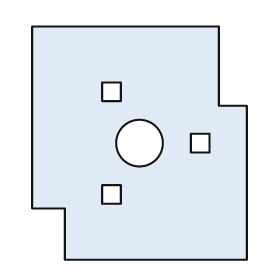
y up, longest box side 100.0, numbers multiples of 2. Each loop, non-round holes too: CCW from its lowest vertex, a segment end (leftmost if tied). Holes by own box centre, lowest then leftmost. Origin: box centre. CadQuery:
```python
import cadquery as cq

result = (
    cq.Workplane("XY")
    .moveTo(-32.0, -50.0)
    .lineTo(46.0, -50.0)
    .lineTo(46.0, 16.0)
    .lineTo(34.0, 16.0)
    .lineTo(34.0, 50.0)
    .lineTo(-46.0, 50.0)
    .lineTo(-46.0, -28.0)
    .lineTo(-32.0, -28.0)
    .close()
    .moveTo(-16.0, -26.0)
    .lineTo(-8.0, -26.0)
    .lineTo(-8.0, -18.0)
    .lineTo(-16.0, -18.0)
    .close()
    .moveTo(0.0, 0.0)
    .circle(10.0)
    .moveTo(22.0, -4.0)
    .lineTo(30.0, -4.0)
    .lineTo(30.0, 4.0)
    .lineTo(22.0, 4.0)
    .close()
    .moveTo(-16.0, 18.0)
    .lineTo(-8.0, 18.0)
    .lineTo(-8.0, 26.0)
    .lineTo(-16.0, 26.0)
    .close()
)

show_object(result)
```